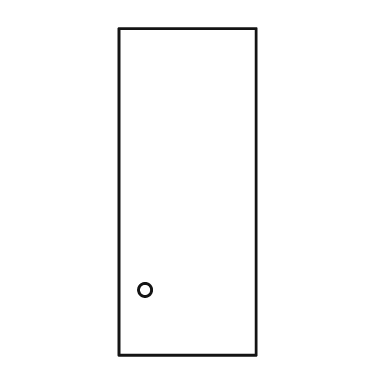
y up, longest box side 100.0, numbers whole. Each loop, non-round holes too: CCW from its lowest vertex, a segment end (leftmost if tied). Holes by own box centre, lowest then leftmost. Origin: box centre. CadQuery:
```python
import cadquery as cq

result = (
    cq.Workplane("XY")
    .moveTo(-21.0, -50.0)
    .lineTo(21.0, -50.0)
    .lineTo(21.0, 50.0)
    .lineTo(-21.0, 50.0)
    .close()
    .moveTo(-13.0, -30.0)
    .circle(2.0)
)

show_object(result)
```